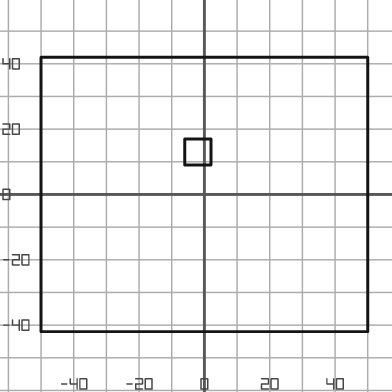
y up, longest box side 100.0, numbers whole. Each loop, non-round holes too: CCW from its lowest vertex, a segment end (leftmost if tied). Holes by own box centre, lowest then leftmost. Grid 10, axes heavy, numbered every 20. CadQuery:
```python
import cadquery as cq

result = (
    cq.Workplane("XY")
    .moveTo(-50.0, -42.0)
    .lineTo(50.0, -42.0)
    .lineTo(50.0, 42.0)
    .lineTo(-50.0, 42.0)
    .close()
    .moveTo(-6.0, 9.0)
    .lineTo(2.0, 9.0)
    .lineTo(2.0, 17.0)
    .lineTo(-6.0, 17.0)
    .close()
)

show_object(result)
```